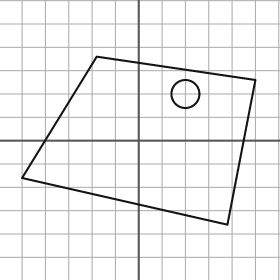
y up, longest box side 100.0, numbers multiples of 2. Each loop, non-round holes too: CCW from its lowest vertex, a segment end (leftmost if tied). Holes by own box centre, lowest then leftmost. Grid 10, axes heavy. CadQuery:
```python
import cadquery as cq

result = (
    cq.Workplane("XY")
    .moveTo(38.0, -36.0)
    .lineTo(50.0, 26.0)
    .lineTo(-18.0, 36.0)
    .lineTo(-50.0, -16.0)
    .close()
    .moveTo(20.0, 20.0)
    .circle(6.0)
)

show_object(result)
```